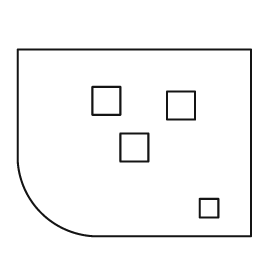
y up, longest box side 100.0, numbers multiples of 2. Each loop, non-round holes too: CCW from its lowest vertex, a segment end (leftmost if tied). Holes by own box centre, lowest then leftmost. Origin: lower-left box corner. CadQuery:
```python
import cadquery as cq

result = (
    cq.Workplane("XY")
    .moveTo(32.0, 0.0)
    .lineTo(100.0, 0.0)
    .lineTo(100.0, 80.0)
    .lineTo(0.0, 80.0)
    .lineTo(0.0, 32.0)
    .threePointArc((10.0, 10.0), (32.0, 0.0))
    .close()
    .moveTo(78.0, 8.0)
    .lineTo(86.0, 8.0)
    .lineTo(86.0, 16.0)
    .lineTo(78.0, 16.0)
    .close()
    .moveTo(44.0, 32.0)
    .lineTo(56.0, 32.0)
    .lineTo(56.0, 44.0)
    .lineTo(44.0, 44.0)
    .close()
    .moveTo(64.0, 50.0)
    .lineTo(76.0, 50.0)
    .lineTo(76.0, 62.0)
    .lineTo(64.0, 62.0)
    .close()
    .moveTo(32.0, 52.0)
    .lineTo(44.0, 52.0)
    .lineTo(44.0, 64.0)
    .lineTo(32.0, 64.0)
    .close()
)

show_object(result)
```